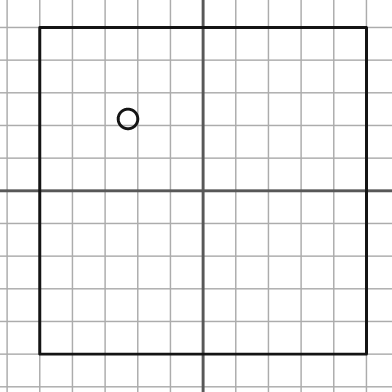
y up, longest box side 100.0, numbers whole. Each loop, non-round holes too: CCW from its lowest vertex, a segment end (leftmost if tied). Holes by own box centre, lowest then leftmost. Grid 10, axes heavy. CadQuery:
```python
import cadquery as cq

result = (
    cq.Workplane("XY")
    .moveTo(-50.0, -50.0)
    .lineTo(50.0, -50.0)
    .lineTo(50.0, 50.0)
    .lineTo(-50.0, 50.0)
    .close()
    .moveTo(-23.0, 22.0)
    .circle(3.0)
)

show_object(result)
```